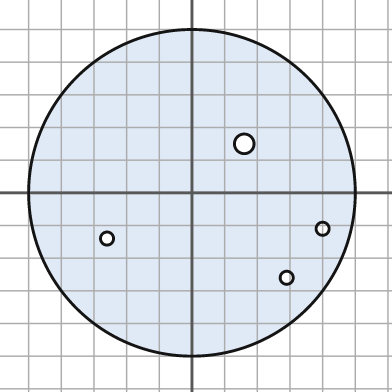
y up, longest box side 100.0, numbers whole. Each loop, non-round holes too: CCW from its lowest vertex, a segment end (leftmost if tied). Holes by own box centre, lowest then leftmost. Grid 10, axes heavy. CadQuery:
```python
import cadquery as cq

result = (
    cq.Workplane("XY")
    .moveTo(0.0, 0.0)
    .circle(50.0)
    .moveTo(29.0, -26.0)
    .circle(2.0)
    .moveTo(-26.0, -14.0)
    .circle(2.0)
    .moveTo(40.0, -11.0)
    .circle(2.0)
    .moveTo(16.0, 15.0)
    .circle(3.0)
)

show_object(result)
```